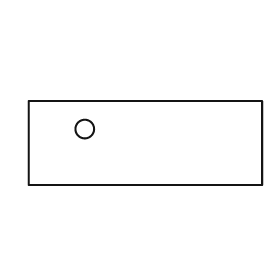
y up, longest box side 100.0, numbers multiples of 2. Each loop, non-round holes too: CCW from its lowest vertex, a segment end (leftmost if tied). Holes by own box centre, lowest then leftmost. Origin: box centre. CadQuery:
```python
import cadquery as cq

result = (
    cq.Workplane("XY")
    .moveTo(-50.0, -18.0)
    .lineTo(50.0, -18.0)
    .lineTo(50.0, 18.0)
    .lineTo(-50.0, 18.0)
    .close()
    .moveTo(-26.0, 6.0)
    .circle(4.0)
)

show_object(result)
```